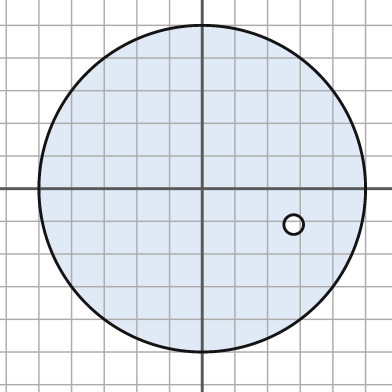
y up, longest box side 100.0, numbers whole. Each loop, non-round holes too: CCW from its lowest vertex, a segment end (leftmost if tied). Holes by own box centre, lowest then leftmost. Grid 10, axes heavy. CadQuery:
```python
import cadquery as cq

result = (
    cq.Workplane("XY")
    .moveTo(0.0, 0.0)
    .circle(50.0)
    .moveTo(28.0, -11.0)
    .circle(3.0)
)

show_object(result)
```